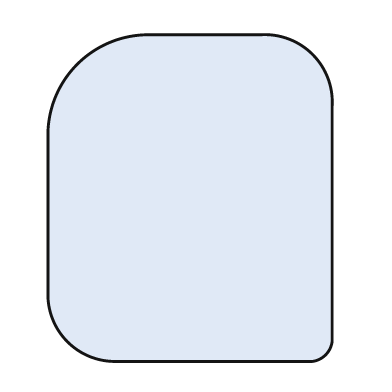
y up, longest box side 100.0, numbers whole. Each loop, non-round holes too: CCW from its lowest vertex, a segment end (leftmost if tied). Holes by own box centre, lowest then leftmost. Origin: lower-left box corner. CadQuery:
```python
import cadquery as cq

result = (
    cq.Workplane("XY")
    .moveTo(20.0, 0.0)
    .lineTo(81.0, 0.0)
    .threePointArc((85.0, 2.0), (87.0, 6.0))
    .lineTo(87.0, 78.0)
    .threePointArc((81.0, 94.0), (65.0, 100.0))
    .lineTo(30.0, 100.0)
    .threePointArc((9.0, 91.0), (0.0, 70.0))
    .lineTo(0.0, 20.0)
    .threePointArc((6.0, 6.0), (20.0, 0.0))
    .close()
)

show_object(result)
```